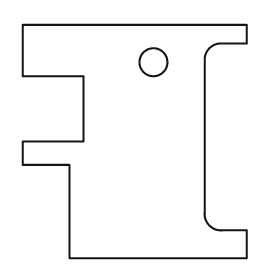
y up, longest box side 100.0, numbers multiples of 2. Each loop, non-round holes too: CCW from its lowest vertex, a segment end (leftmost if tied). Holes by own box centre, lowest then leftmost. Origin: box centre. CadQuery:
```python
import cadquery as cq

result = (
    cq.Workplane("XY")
    .moveTo(-28.0, -50.0)
    .lineTo(48.0, -50.0)
    .lineTo(48.0, -38.0)
    .lineTo(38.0, -38.0)
    .threePointArc((32.0, -36.0), (30.0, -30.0))
    .lineTo(30.0, 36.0)
    .threePointArc((32.0, 40.0), (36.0, 42.0))
    .lineTo(48.0, 42.0)
    .lineTo(48.0, 50.0)
    .lineTo(-48.0, 50.0)
    .lineTo(-48.0, 28.0)
    .lineTo(-22.0, 28.0)
    .lineTo(-22.0, 0.0)
    .lineTo(-48.0, 0.0)
    .lineTo(-48.0, -10.0)
    .lineTo(-28.0, -10.0)
    .close()
    .moveTo(8.0, 34.0)
    .circle(6.0)
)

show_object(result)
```